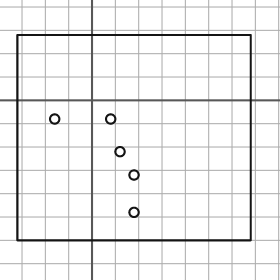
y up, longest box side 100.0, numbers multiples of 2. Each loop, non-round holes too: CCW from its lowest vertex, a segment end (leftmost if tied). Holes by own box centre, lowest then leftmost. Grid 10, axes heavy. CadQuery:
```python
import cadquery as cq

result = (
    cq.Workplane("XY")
    .moveTo(-32.0, -60.0)
    .lineTo(68.0, -60.0)
    .lineTo(68.0, 28.0)
    .lineTo(-32.0, 28.0)
    .close()
    .moveTo(18.0, -48.0)
    .circle(2.0)
    .moveTo(18.0, -32.0)
    .circle(2.0)
    .moveTo(12.0, -22.0)
    .circle(2.0)
    .moveTo(-16.0, -8.0)
    .circle(2.0)
    .moveTo(8.0, -8.0)
    .circle(2.0)
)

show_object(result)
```